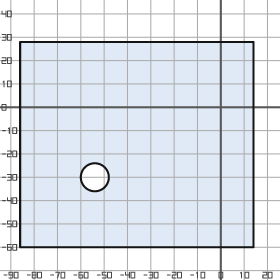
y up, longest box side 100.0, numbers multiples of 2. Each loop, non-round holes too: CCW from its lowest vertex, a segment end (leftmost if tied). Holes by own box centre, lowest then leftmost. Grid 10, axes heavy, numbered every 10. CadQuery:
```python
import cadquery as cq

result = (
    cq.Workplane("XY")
    .moveTo(-86.0, -60.0)
    .lineTo(14.0, -60.0)
    .lineTo(14.0, 28.0)
    .lineTo(-86.0, 28.0)
    .close()
    .moveTo(-54.0, -30.0)
    .circle(6.0)
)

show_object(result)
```